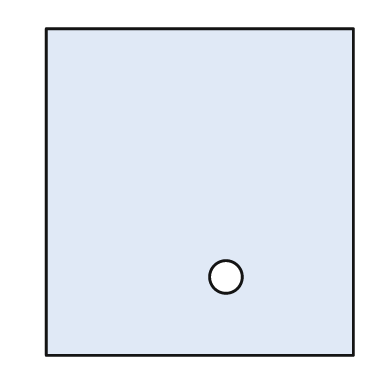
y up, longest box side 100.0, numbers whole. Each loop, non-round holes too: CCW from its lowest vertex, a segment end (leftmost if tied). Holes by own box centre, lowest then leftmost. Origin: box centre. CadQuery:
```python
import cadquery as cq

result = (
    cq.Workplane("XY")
    .moveTo(-47.0, -50.0)
    .lineTo(47.0, -50.0)
    .lineTo(47.0, 50.0)
    .lineTo(-47.0, 50.0)
    .close()
    .moveTo(8.0, -26.0)
    .circle(5.0)
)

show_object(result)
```